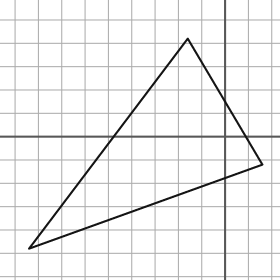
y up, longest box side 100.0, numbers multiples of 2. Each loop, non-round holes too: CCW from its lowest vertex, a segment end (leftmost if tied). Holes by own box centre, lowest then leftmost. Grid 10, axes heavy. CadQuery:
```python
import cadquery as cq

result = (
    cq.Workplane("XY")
    .moveTo(-84.0, -48.0)
    .lineTo(16.0, -12.0)
    .lineTo(-16.0, 42.0)
    .close()
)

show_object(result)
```